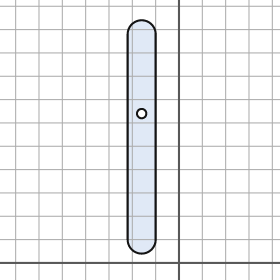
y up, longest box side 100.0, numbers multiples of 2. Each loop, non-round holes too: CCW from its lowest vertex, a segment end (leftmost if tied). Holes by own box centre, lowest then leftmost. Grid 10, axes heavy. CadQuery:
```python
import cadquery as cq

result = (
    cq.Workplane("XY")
    .moveTo(-22.0, 10.0)
    .threePointArc((-16.0, 4.0), (-10.0, 10.0))
    .lineTo(-10.0, 98.0)
    .threePointArc((-16.0, 104.0), (-22.0, 98.0))
    .close()
    .moveTo(-16.0, 64.0)
    .circle(2.0)
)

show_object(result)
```